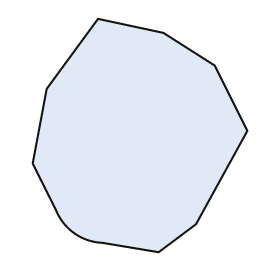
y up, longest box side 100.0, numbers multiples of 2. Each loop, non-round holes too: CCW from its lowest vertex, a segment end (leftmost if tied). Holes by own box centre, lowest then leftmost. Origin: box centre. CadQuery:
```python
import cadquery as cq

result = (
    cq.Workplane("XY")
    .moveTo(8.0, -50.0)
    .lineTo(24.0, -38.0)
    .lineTo(46.0, 2.0)
    .lineTo(32.0, 30.0)
    .lineTo(10.0, 44.0)
    .lineTo(-18.0, 50.0)
    .lineTo(-40.0, 20.0)
    .lineTo(-46.0, -12.0)
    .lineTo(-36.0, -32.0)
    .threePointArc((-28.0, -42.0), (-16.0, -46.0))
    .close()
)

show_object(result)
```